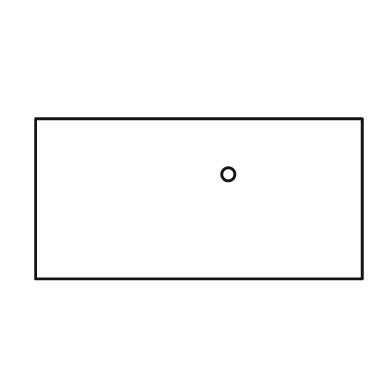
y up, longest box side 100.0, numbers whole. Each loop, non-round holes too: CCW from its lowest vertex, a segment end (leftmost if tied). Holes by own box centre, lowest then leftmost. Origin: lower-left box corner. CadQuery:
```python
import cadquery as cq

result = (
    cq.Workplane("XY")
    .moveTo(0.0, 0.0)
    .lineTo(100.0, 0.0)
    .lineTo(100.0, 49.0)
    .lineTo(0.0, 49.0)
    .close()
    .moveTo(59.0, 32.0)
    .circle(2.0)
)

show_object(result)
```